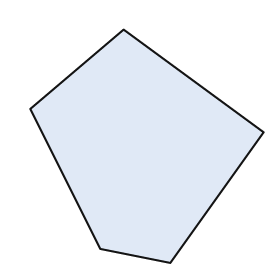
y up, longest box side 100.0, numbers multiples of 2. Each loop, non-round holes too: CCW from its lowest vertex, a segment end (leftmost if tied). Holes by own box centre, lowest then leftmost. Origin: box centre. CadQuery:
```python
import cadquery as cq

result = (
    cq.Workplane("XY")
    .moveTo(10.0, -50.0)
    .lineTo(50.0, 6.0)
    .lineTo(-10.0, 50.0)
    .lineTo(-50.0, 16.0)
    .lineTo(-20.0, -44.0)
    .close()
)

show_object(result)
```